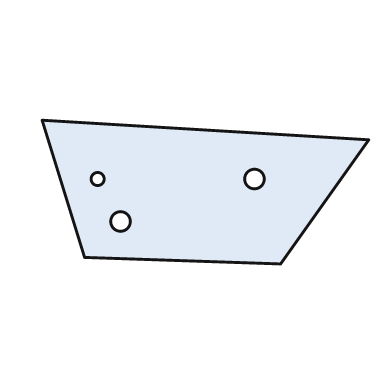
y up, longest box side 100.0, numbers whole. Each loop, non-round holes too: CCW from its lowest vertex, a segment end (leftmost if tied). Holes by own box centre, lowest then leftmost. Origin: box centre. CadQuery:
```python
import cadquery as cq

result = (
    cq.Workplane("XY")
    .moveTo(23.0, -22.0)
    .lineTo(50.0, 16.0)
    .lineTo(-50.0, 22.0)
    .lineTo(-37.0, -20.0)
    .close()
    .moveTo(-26.0, -9.0)
    .circle(3.0)
    .moveTo(-33.0, 4.0)
    .circle(2.0)
    .moveTo(15.0, 4.0)
    .circle(3.0)
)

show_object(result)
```